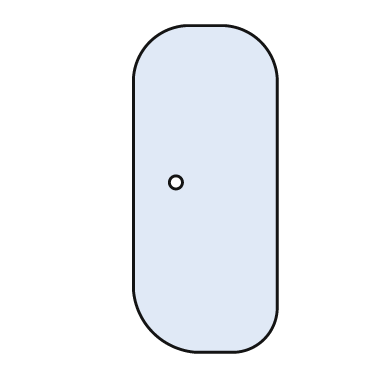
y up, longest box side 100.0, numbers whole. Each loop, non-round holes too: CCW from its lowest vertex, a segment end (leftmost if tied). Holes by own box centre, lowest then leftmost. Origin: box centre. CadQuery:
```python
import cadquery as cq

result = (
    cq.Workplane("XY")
    .moveTo(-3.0, -50.0)
    .lineTo(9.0, -50.0)
    .threePointArc((18.0, -46.0), (22.0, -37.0))
    .lineTo(22.0, 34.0)
    .threePointArc((17.0, 45.0), (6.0, 50.0))
    .lineTo(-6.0, 50.0)
    .threePointArc((-17.0, 45.0), (-22.0, 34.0))
    .lineTo(-22.0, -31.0)
    .threePointArc((-16.0, -44.0), (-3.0, -50.0))
    .close()
    .moveTo(-9.0, 2.0)
    .circle(2.0)
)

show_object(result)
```